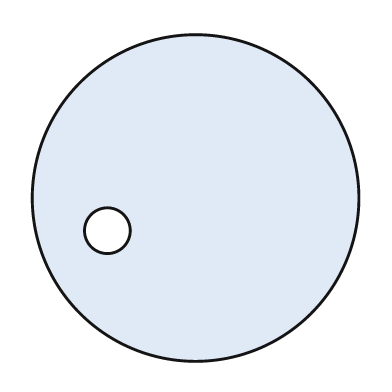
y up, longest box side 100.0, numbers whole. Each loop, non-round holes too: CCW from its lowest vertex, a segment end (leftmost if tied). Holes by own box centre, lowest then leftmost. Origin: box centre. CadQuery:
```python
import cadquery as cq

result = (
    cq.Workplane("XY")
    .moveTo(0.0, 0.0)
    .circle(50.0)
    .moveTo(-27.0, -10.0)
    .circle(7.0)
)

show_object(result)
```